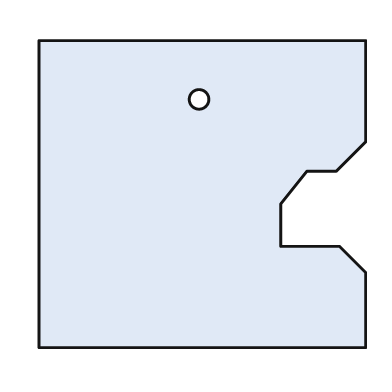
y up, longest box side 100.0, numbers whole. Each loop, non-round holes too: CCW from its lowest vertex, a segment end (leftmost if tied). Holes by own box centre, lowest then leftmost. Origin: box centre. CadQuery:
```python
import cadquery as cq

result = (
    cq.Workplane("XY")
    .moveTo(-50.0, -47.0)
    .lineTo(50.0, -47.0)
    .lineTo(50.0, -24.0)
    .lineTo(42.0, -16.0)
    .lineTo(24.0, -16.0)
    .lineTo(24.0, -3.0)
    .lineTo(32.0, 7.0)
    .lineTo(41.0, 7.0)
    .lineTo(50.0, 16.0)
    .lineTo(50.0, 47.0)
    .lineTo(-50.0, 47.0)
    .close()
    .moveTo(-1.0, 29.0)
    .circle(3.0)
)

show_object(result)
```